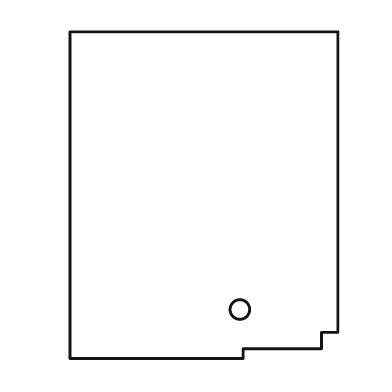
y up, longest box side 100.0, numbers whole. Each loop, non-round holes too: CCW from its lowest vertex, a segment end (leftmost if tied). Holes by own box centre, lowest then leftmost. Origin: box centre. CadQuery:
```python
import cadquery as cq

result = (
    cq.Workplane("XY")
    .moveTo(-41.0, -50.0)
    .lineTo(12.0, -50.0)
    .lineTo(12.0, -47.0)
    .lineTo(36.0, -47.0)
    .lineTo(36.0, -42.0)
    .lineTo(41.0, -42.0)
    .lineTo(41.0, 50.0)
    .lineTo(-41.0, 50.0)
    .close()
    .moveTo(11.0, -35.0)
    .circle(3.0)
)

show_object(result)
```